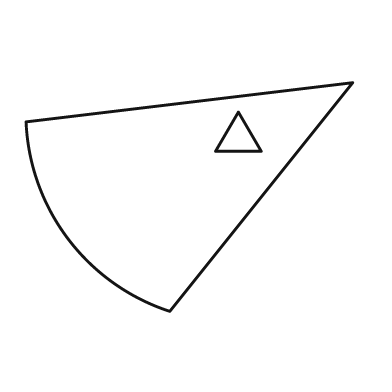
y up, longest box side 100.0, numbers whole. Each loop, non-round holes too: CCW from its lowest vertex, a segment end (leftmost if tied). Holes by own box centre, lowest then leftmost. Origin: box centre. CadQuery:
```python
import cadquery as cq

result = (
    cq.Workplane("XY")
    .moveTo(-6.0, -35.0)
    .lineTo(50.0, 35.0)
    .lineTo(-50.0, 23.0)
    .threePointArc((-37.0, -13.0), (-6.0, -35.0))
    .close()
    .moveTo(8.0, 14.0)
    .lineTo(22.0, 14.0)
    .lineTo(15.0, 26.0)
    .close()
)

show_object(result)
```